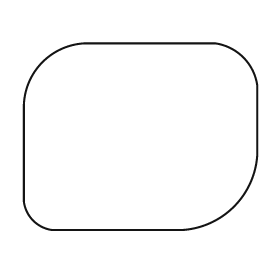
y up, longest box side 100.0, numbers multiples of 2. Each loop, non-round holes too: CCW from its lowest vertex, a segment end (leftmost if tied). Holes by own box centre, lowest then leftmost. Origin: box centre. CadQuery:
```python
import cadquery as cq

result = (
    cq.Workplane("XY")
    .moveTo(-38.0, -40.0)
    .lineTo(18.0, -40.0)
    .threePointArc((40.0, -30.0), (50.0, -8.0))
    .lineTo(50.0, 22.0)
    .threePointArc((44.0, 34.0), (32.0, 40.0))
    .lineTo(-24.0, 40.0)
    .threePointArc((-42.0, 32.0), (-50.0, 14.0))
    .lineTo(-50.0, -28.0)
    .threePointArc((-46.0, -36.0), (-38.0, -40.0))
    .close()
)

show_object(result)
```